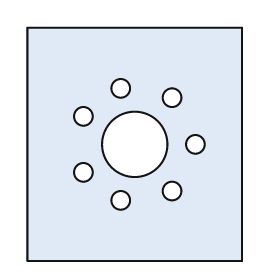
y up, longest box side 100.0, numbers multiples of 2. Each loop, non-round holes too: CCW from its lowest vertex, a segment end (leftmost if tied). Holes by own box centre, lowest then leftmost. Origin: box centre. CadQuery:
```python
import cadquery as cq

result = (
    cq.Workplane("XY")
    .moveTo(-46.0, -50.0)
    .lineTo(46.0, -50.0)
    .lineTo(46.0, 50.0)
    .lineTo(-46.0, 50.0)
    .close()
    .moveTo(-6.0, -24.0)
    .circle(4.0)
    .moveTo(16.0, -20.0)
    .circle(4.0)
    .moveTo(-22.0, -12.0)
    .circle(4.0)
    .moveTo(0.0, 0.0)
    .circle(14.0)
    .moveTo(26.0, 0.0)
    .circle(4.0)
    .moveTo(-22.0, 12.0)
    .circle(4.0)
    .moveTo(16.0, 20.0)
    .circle(4.0)
    .moveTo(-6.0, 24.0)
    .circle(4.0)
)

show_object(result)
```